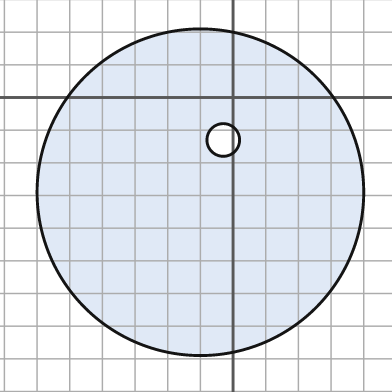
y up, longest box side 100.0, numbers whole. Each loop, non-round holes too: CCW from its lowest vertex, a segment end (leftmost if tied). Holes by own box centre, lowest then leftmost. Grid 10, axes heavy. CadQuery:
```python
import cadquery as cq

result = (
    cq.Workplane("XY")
    .moveTo(-10.0, -29.0)
    .circle(50.0)
    .moveTo(-3.0, -13.0)
    .circle(5.0)
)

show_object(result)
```